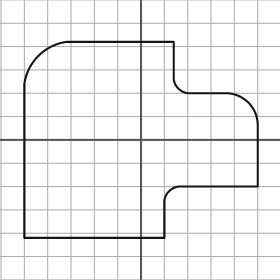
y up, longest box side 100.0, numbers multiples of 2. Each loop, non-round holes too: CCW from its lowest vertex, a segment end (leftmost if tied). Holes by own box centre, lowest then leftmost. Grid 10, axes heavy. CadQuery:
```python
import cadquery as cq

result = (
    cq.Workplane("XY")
    .moveTo(-50.0, -42.0)
    .lineTo(10.0, -42.0)
    .lineTo(10.0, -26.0)
    .threePointArc((12.0, -22.0), (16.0, -20.0))
    .lineTo(50.0, -20.0)
    .lineTo(50.0, 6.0)
    .threePointArc((46.0, 16.0), (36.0, 20.0))
    .lineTo(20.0, 20.0)
    .threePointArc((16.0, 22.0), (14.0, 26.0))
    .lineTo(14.0, 42.0)
    .lineTo(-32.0, 42.0)
    .threePointArc((-44.0, 36.0), (-50.0, 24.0))
    .close()
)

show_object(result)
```